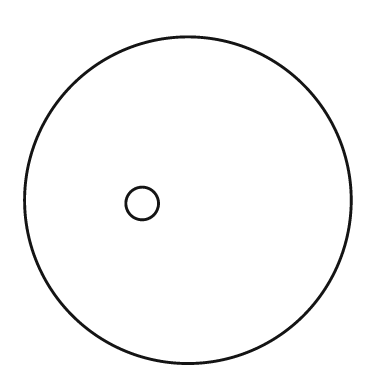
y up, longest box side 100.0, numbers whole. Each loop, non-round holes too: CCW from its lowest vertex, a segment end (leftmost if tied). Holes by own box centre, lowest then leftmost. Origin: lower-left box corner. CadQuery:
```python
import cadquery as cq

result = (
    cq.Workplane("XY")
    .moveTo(50.0, 50.0)
    .circle(50.0)
    .moveTo(36.0, 49.0)
    .circle(5.0)
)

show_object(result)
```